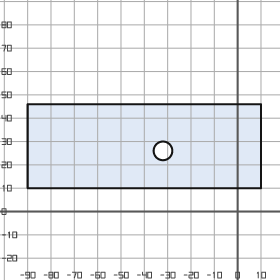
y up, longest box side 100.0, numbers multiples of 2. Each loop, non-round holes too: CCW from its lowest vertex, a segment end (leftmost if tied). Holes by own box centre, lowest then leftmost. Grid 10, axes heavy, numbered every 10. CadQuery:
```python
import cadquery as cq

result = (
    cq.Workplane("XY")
    .moveTo(-90.0, 10.0)
    .lineTo(10.0, 10.0)
    .lineTo(10.0, 46.0)
    .lineTo(-90.0, 46.0)
    .close()
    .moveTo(-32.0, 26.0)
    .circle(4.0)
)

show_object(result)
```